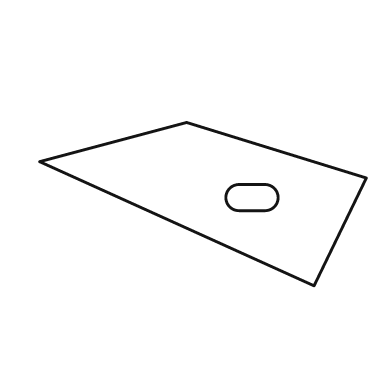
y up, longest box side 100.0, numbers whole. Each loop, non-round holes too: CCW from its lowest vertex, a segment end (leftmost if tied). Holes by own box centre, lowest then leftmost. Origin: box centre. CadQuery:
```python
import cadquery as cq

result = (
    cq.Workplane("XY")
    .moveTo(34.0, -25.0)
    .lineTo(50.0, 8.0)
    .lineTo(-5.0, 25.0)
    .lineTo(-50.0, 13.0)
    .close()
    .moveTo(11.0, -2.0)
    .lineTo(19.0, -2.0)
    .threePointArc((23.0, 2.0), (19.0, 6.0))
    .lineTo(11.0, 6.0)
    .threePointArc((7.0, 2.0), (11.0, -2.0))
    .close()
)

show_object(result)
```